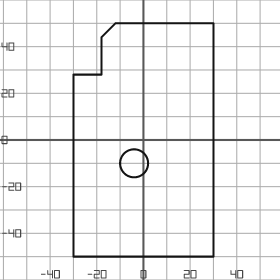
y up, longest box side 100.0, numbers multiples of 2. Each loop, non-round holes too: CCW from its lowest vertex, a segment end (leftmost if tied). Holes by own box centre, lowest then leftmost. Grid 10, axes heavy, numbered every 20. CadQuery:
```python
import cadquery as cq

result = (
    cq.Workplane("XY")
    .moveTo(-30.0, -50.0)
    .lineTo(30.0, -50.0)
    .lineTo(30.0, 50.0)
    .lineTo(-12.0, 50.0)
    .lineTo(-18.0, 44.0)
    .lineTo(-18.0, 28.0)
    .lineTo(-30.0, 28.0)
    .close()
    .moveTo(-4.0, -10.0)
    .circle(6.0)
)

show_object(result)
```